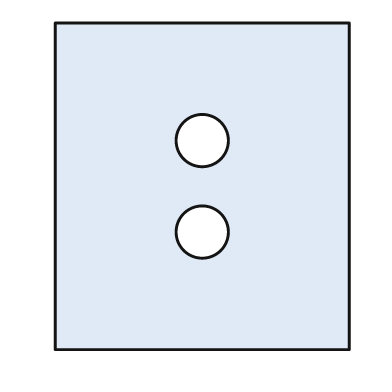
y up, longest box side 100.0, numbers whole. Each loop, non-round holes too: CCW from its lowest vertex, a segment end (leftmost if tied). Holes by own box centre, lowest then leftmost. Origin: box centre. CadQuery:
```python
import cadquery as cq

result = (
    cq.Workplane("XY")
    .moveTo(-45.0, -50.0)
    .lineTo(45.0, -50.0)
    .lineTo(45.0, 50.0)
    .lineTo(-45.0, 50.0)
    .close()
    .moveTo(0.0, -14.0)
    .circle(8.0)
    .moveTo(0.0, 14.0)
    .circle(8.0)
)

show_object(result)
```